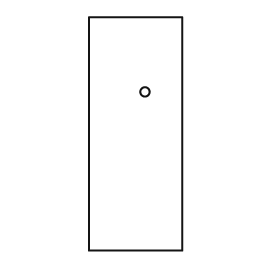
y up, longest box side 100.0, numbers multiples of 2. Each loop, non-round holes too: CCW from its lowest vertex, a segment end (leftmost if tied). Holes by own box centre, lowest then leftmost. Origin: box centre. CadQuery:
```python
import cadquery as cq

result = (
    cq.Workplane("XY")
    .moveTo(-20.0, -50.0)
    .lineTo(20.0, -50.0)
    .lineTo(20.0, 50.0)
    .lineTo(-20.0, 50.0)
    .close()
    .moveTo(4.0, 18.0)
    .circle(2.0)
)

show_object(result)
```